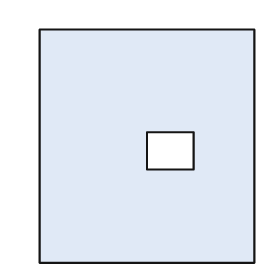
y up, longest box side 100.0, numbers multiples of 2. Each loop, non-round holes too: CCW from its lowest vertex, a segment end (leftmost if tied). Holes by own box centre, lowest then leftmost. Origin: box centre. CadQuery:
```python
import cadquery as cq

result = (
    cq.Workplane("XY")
    .moveTo(-46.0, -50.0)
    .lineTo(46.0, -50.0)
    .lineTo(46.0, 50.0)
    .lineTo(-46.0, 50.0)
    .close()
    .moveTo(0.0, -10.0)
    .lineTo(20.0, -10.0)
    .lineTo(20.0, 6.0)
    .lineTo(0.0, 6.0)
    .close()
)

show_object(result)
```